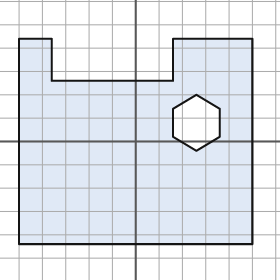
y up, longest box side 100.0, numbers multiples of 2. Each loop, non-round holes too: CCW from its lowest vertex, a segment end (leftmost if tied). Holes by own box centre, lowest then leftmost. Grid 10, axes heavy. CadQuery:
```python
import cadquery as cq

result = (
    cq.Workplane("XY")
    .moveTo(-50.0, -44.0)
    .lineTo(50.0, -44.0)
    .lineTo(50.0, 44.0)
    .lineTo(16.0, 44.0)
    .lineTo(16.0, 26.0)
    .lineTo(-36.0, 26.0)
    .lineTo(-36.0, 44.0)
    .lineTo(-50.0, 44.0)
    .close()
    .moveTo(26.0, -4.0)
    .lineTo(36.0, 2.0)
    .lineTo(36.0, 14.0)
    .lineTo(26.0, 20.0)
    .lineTo(16.0, 14.0)
    .lineTo(16.0, 2.0)
    .close()
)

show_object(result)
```